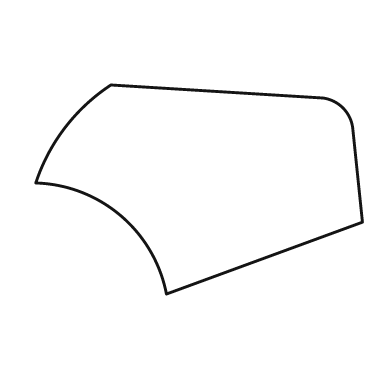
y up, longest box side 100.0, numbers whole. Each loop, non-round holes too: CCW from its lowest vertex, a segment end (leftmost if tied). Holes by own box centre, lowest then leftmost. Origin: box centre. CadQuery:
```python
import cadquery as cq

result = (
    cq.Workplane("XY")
    .moveTo(-10.0, -32.0)
    .lineTo(50.0, -10.0)
    .lineTo(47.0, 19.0)
    .threePointArc((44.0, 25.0), (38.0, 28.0))
    .lineTo(-27.0, 32.0)
    .threePointArc((-41.0, 19.0), (-50.0, 2.0))
    .threePointArc((-24.0, -8.0), (-10.0, -32.0))
    .close()
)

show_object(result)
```